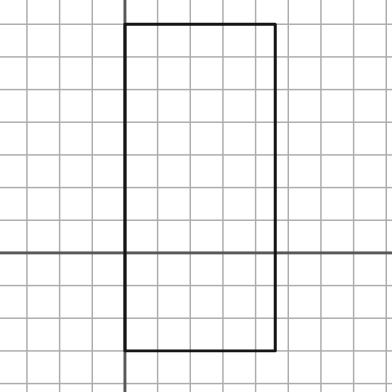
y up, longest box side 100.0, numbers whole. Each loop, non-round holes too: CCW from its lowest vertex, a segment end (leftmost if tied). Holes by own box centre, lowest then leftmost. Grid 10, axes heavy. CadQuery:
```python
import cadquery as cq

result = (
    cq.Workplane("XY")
    .moveTo(0.0, -30.0)
    .lineTo(46.0, -30.0)
    .lineTo(46.0, 70.0)
    .lineTo(0.0, 70.0)
    .close()
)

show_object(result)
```